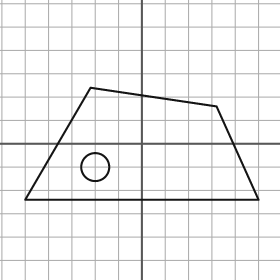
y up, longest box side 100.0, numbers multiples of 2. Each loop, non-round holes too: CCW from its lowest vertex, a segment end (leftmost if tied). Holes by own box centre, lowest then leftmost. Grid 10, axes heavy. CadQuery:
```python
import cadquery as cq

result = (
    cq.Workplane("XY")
    .moveTo(-50.0, -24.0)
    .lineTo(50.0, -24.0)
    .lineTo(32.0, 16.0)
    .lineTo(-22.0, 24.0)
    .close()
    .moveTo(-20.0, -10.0)
    .circle(6.0)
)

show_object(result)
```